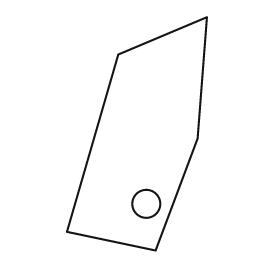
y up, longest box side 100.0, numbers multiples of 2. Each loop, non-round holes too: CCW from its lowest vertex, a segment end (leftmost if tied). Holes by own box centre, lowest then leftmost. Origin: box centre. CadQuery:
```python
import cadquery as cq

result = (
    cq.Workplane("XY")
    .moveTo(8.0, -50.0)
    .lineTo(26.0, -2.0)
    .lineTo(30.0, 50.0)
    .lineTo(-8.0, 34.0)
    .lineTo(-30.0, -42.0)
    .close()
    .moveTo(4.0, -30.0)
    .circle(6.0)
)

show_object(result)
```